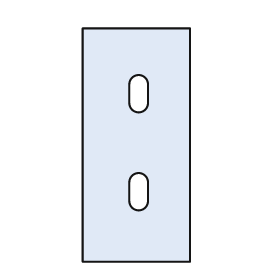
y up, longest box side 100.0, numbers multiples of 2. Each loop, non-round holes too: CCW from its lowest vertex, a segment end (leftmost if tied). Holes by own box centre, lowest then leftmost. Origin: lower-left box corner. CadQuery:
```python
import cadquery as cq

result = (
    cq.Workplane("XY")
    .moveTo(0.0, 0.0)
    .lineTo(46.0, 0.0)
    .lineTo(46.0, 100.0)
    .lineTo(0.0, 100.0)
    .close()
    .moveTo(20.0, 26.0)
    .threePointArc((24.0, 22.0), (28.0, 26.0))
    .lineTo(28.0, 34.0)
    .threePointArc((24.0, 38.0), (20.0, 34.0))
    .close()
    .moveTo(20.0, 68.0)
    .threePointArc((24.0, 64.0), (28.0, 68.0))
    .lineTo(28.0, 76.0)
    .threePointArc((24.0, 80.0), (20.0, 76.0))
    .close()
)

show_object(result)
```